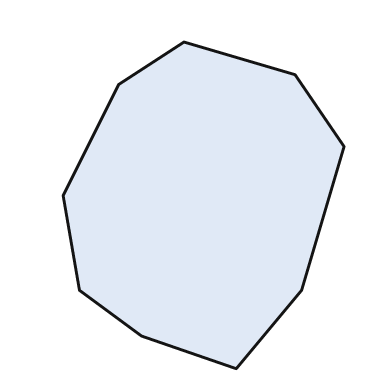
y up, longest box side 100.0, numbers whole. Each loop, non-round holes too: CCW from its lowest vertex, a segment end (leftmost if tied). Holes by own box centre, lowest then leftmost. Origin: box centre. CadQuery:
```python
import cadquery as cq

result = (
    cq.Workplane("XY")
    .moveTo(10.0, -50.0)
    .lineTo(30.0, -26.0)
    .lineTo(43.0, 18.0)
    .lineTo(28.0, 40.0)
    .lineTo(-6.0, 50.0)
    .lineTo(-26.0, 37.0)
    .lineTo(-43.0, 3.0)
    .lineTo(-38.0, -26.0)
    .lineTo(-19.0, -40.0)
    .close()
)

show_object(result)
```